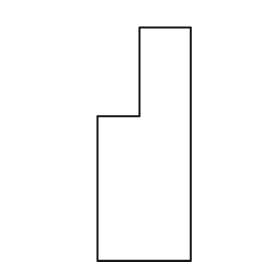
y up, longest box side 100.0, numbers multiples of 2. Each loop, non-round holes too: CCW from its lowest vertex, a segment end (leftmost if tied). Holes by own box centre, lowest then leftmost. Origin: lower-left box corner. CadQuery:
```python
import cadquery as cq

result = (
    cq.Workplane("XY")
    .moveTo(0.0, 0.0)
    .lineTo(40.0, 0.0)
    .lineTo(40.0, 100.0)
    .lineTo(18.0, 100.0)
    .lineTo(18.0, 62.0)
    .lineTo(0.0, 62.0)
    .close()
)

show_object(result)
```